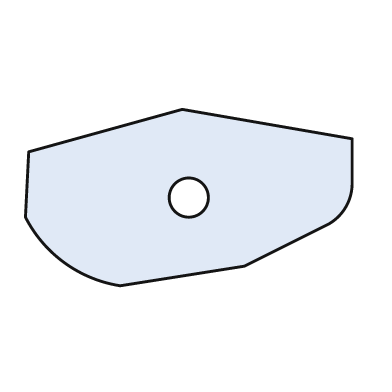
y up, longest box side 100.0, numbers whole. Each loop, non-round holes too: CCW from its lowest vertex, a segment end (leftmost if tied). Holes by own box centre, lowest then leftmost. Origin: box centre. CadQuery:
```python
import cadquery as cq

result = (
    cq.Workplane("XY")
    .moveTo(-21.0, -27.0)
    .lineTo(17.0, -21.0)
    .lineTo(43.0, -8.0)
    .threePointArc((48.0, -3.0), (50.0, 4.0))
    .lineTo(50.0, 18.0)
    .lineTo(-2.0, 27.0)
    .lineTo(-49.0, 14.0)
    .lineTo(-50.0, -6.0)
    .threePointArc((-38.0, -20.0), (-21.0, -27.0))
    .close()
    .moveTo(0.0, 0.0)
    .circle(6.0)
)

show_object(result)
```